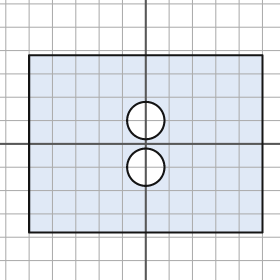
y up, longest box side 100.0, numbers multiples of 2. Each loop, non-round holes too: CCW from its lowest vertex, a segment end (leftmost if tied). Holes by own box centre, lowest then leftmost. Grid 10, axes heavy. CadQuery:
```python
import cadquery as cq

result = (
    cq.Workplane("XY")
    .moveTo(-50.0, -38.0)
    .lineTo(50.0, -38.0)
    .lineTo(50.0, 38.0)
    .lineTo(-50.0, 38.0)
    .close()
    .moveTo(0.0, -10.0)
    .circle(8.0)
    .moveTo(0.0, 10.0)
    .circle(8.0)
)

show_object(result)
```